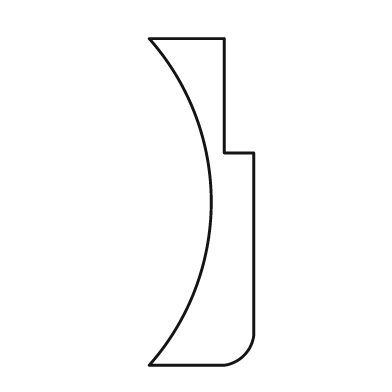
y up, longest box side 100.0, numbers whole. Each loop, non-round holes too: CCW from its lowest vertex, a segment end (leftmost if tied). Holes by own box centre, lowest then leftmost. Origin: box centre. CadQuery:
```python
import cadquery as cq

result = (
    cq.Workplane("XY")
    .moveTo(-16.0, -50.0)
    .lineTo(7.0, -50.0)
    .threePointArc((13.0, -47.0), (16.0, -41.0))
    .lineTo(16.0, 15.0)
    .lineTo(7.0, 15.0)
    .lineTo(7.0, 50.0)
    .lineTo(-16.0, 50.0)
    .threePointArc((3.0, 0.0), (-16.0, -50.0))
    .close()
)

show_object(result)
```